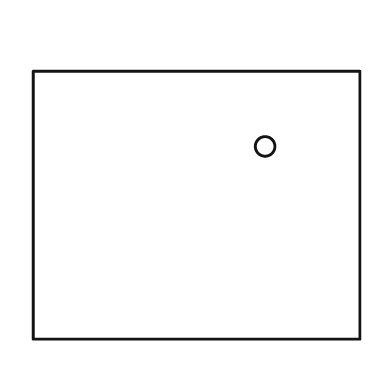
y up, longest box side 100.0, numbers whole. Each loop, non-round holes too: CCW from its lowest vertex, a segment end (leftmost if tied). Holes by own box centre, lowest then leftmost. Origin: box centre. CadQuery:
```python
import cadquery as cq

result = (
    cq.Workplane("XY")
    .moveTo(-50.0, -41.0)
    .lineTo(50.0, -41.0)
    .lineTo(50.0, 41.0)
    .lineTo(-50.0, 41.0)
    .close()
    .moveTo(21.0, 18.0)
    .circle(3.0)
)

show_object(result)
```